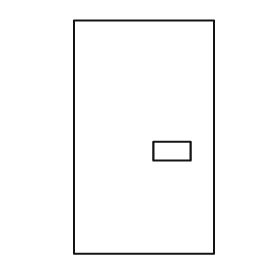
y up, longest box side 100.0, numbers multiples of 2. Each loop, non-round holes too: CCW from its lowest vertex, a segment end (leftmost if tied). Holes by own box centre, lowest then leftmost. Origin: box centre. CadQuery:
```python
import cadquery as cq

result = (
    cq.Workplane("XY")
    .moveTo(-30.0, -50.0)
    .lineTo(30.0, -50.0)
    .lineTo(30.0, 50.0)
    .lineTo(-30.0, 50.0)
    .close()
    .moveTo(4.0, -10.0)
    .lineTo(20.0, -10.0)
    .lineTo(20.0, -2.0)
    .lineTo(4.0, -2.0)
    .close()
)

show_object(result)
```